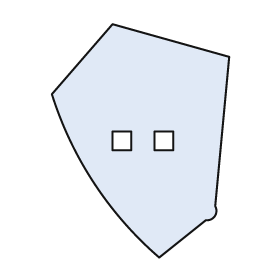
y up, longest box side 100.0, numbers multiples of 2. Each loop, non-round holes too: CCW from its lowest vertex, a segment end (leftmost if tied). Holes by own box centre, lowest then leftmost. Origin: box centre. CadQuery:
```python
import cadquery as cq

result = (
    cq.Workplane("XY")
    .moveTo(8.0, -50.0)
    .lineTo(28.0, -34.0)
    .threePointArc((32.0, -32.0), (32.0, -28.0))
    .lineTo(38.0, 36.0)
    .lineTo(-12.0, 50.0)
    .lineTo(-38.0, 20.0)
    .threePointArc((-20.0, -18.0), (8.0, -50.0))
    .close()
    .moveTo(-12.0, -4.0)
    .lineTo(-4.0, -4.0)
    .lineTo(-4.0, 4.0)
    .lineTo(-12.0, 4.0)
    .close()
    .moveTo(6.0, -4.0)
    .lineTo(14.0, -4.0)
    .lineTo(14.0, 4.0)
    .lineTo(6.0, 4.0)
    .close()
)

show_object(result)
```